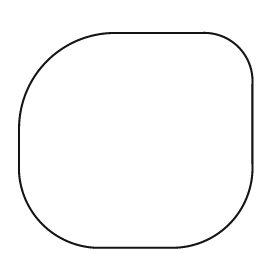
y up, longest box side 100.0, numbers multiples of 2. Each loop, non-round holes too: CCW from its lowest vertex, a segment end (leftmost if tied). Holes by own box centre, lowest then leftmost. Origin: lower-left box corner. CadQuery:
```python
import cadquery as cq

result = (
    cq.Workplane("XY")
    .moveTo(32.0, 0.0)
    .lineTo(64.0, 0.0)
    .threePointArc((90.0, 10.0), (100.0, 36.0))
    .lineTo(100.0, 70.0)
    .threePointArc((94.0, 86.0), (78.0, 92.0))
    .lineTo(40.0, 92.0)
    .threePointArc((12.0, 80.0), (0.0, 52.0))
    .lineTo(0.0, 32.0)
    .threePointArc((10.0, 10.0), (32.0, 0.0))
    .close()
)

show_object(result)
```